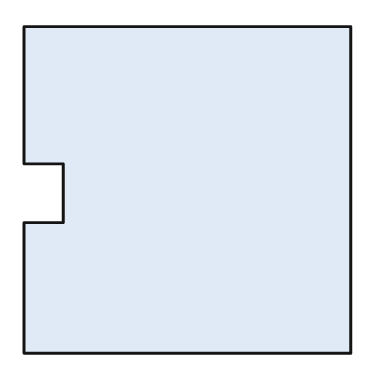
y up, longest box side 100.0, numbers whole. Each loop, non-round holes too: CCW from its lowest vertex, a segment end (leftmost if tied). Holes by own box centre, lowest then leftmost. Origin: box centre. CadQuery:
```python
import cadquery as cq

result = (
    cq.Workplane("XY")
    .moveTo(-50.0, -50.0)
    .lineTo(50.0, -50.0)
    .lineTo(50.0, 50.0)
    .lineTo(-50.0, 50.0)
    .lineTo(-50.0, 8.0)
    .lineTo(-38.0, 8.0)
    .lineTo(-38.0, -10.0)
    .lineTo(-50.0, -10.0)
    .close()
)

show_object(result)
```